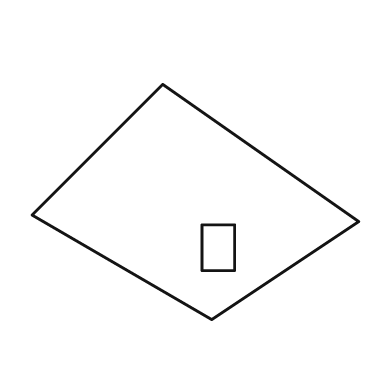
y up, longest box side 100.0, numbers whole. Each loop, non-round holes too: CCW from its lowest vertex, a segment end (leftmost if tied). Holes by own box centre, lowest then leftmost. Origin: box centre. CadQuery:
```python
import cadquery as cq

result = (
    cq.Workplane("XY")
    .moveTo(5.0, -36.0)
    .lineTo(50.0, -6.0)
    .lineTo(-10.0, 36.0)
    .lineTo(-50.0, -4.0)
    .close()
    .moveTo(2.0, -21.0)
    .lineTo(12.0, -21.0)
    .lineTo(12.0, -7.0)
    .lineTo(2.0, -7.0)
    .close()
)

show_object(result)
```